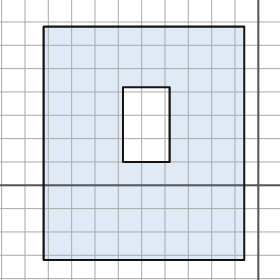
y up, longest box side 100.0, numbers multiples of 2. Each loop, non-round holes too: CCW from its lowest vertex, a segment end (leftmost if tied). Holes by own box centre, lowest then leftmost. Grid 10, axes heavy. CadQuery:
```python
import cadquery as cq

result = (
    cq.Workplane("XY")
    .moveTo(-92.0, -32.0)
    .lineTo(-6.0, -32.0)
    .lineTo(-6.0, 68.0)
    .lineTo(-92.0, 68.0)
    .close()
    .moveTo(-58.0, 10.0)
    .lineTo(-38.0, 10.0)
    .lineTo(-38.0, 42.0)
    .lineTo(-58.0, 42.0)
    .close()
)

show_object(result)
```